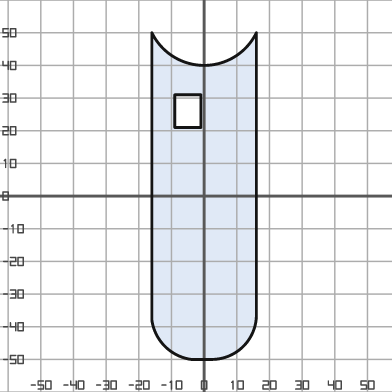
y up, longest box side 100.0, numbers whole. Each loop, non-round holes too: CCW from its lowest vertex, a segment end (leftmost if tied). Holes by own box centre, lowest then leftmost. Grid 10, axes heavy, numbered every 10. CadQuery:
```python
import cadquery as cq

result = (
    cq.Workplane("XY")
    .moveTo(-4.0, -50.0)
    .lineTo(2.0, -50.0)
    .threePointArc((12.0, -46.0), (16.0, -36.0))
    .lineTo(16.0, 50.0)
    .threePointArc((0.0, 40.0), (-16.0, 50.0))
    .lineTo(-16.0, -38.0)
    .threePointArc((-12.0, -46.0), (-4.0, -50.0))
    .close()
    .moveTo(-9.0, 21.0)
    .lineTo(-1.0, 21.0)
    .lineTo(-1.0, 31.0)
    .lineTo(-9.0, 31.0)
    .close()
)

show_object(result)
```